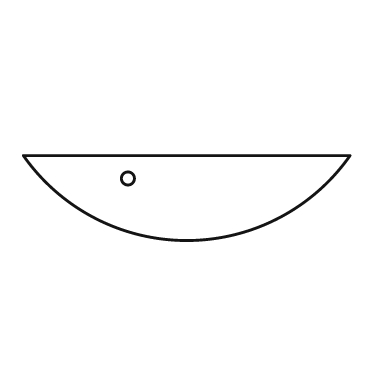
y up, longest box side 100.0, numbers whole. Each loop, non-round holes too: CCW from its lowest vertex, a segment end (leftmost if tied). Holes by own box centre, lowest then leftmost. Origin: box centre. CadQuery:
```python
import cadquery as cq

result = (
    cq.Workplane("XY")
    .moveTo(-50.0, 13.0)
    .threePointArc((0.0, -13.0), (50.0, 13.0))
    .close()
    .moveTo(-18.0, 6.0)
    .circle(2.0)
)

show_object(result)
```